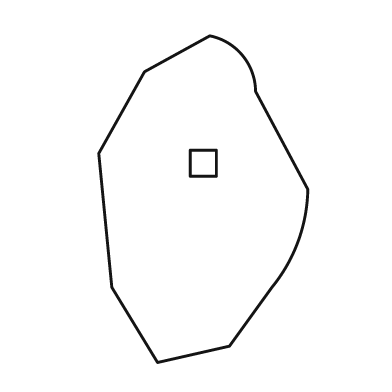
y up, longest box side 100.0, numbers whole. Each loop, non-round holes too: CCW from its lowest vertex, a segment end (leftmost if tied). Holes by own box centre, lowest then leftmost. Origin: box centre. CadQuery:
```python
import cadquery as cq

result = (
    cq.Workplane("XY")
    .moveTo(-14.0, -50.0)
    .lineTo(8.0, -45.0)
    .lineTo(21.0, -27.0)
    .threePointArc((29.0, -13.0), (32.0, 3.0))
    .lineTo(16.0, 33.0)
    .threePointArc((12.0, 44.0), (2.0, 50.0))
    .lineTo(-18.0, 39.0)
    .lineTo(-32.0, 14.0)
    .lineTo(-28.0, -27.0)
    .close()
    .moveTo(-4.0, 7.0)
    .lineTo(4.0, 7.0)
    .lineTo(4.0, 15.0)
    .lineTo(-4.0, 15.0)
    .close()
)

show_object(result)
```